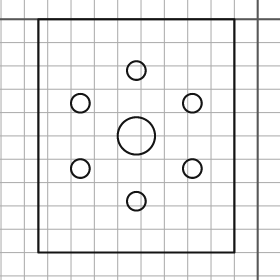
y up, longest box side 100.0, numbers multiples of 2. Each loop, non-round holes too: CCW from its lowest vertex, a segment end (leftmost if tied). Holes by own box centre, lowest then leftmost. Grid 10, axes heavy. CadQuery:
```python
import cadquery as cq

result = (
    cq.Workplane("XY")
    .moveTo(-94.0, -100.0)
    .lineTo(-10.0, -100.0)
    .lineTo(-10.0, 0.0)
    .lineTo(-94.0, 0.0)
    .close()
    .moveTo(-52.0, -78.0)
    .circle(4.0)
    .moveTo(-76.0, -64.0)
    .circle(4.0)
    .moveTo(-28.0, -64.0)
    .circle(4.0)
    .moveTo(-52.0, -50.0)
    .circle(8.0)
    .moveTo(-76.0, -36.0)
    .circle(4.0)
    .moveTo(-28.0, -36.0)
    .circle(4.0)
    .moveTo(-52.0, -22.0)
    .circle(4.0)
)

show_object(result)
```